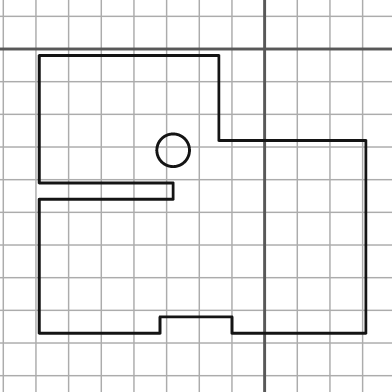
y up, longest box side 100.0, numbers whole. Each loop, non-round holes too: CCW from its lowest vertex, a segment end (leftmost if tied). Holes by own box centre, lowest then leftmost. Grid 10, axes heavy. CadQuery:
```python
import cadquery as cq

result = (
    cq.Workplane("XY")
    .moveTo(-69.0, -87.0)
    .lineTo(-32.0, -87.0)
    .lineTo(-32.0, -82.0)
    .lineTo(-10.0, -82.0)
    .lineTo(-10.0, -87.0)
    .lineTo(31.0, -87.0)
    .lineTo(31.0, -28.0)
    .lineTo(-14.0, -28.0)
    .lineTo(-14.0, -2.0)
    .lineTo(-69.0, -2.0)
    .lineTo(-69.0, -41.0)
    .lineTo(-28.0, -41.0)
    .lineTo(-28.0, -46.0)
    .lineTo(-69.0, -46.0)
    .close()
    .moveTo(-28.0, -31.0)
    .circle(5.0)
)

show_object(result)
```